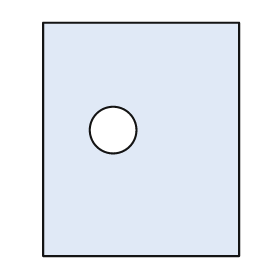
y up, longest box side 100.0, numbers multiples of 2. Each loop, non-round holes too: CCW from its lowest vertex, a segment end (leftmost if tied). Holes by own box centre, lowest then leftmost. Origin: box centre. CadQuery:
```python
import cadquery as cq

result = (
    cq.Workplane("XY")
    .moveTo(-42.0, -50.0)
    .lineTo(42.0, -50.0)
    .lineTo(42.0, 50.0)
    .lineTo(-42.0, 50.0)
    .close()
    .moveTo(-12.0, 4.0)
    .circle(10.0)
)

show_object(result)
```